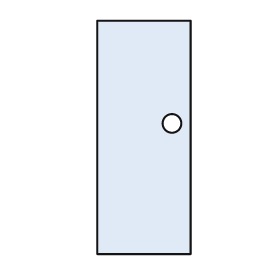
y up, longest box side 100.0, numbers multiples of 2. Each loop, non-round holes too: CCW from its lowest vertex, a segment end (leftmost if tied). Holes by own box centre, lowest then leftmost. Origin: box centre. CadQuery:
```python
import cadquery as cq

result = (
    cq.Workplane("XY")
    .moveTo(-20.0, -50.0)
    .lineTo(20.0, -50.0)
    .lineTo(20.0, 50.0)
    .lineTo(-20.0, 50.0)
    .close()
    .moveTo(12.0, 6.0)
    .circle(4.0)
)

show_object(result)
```